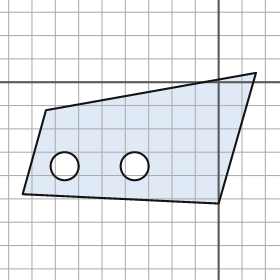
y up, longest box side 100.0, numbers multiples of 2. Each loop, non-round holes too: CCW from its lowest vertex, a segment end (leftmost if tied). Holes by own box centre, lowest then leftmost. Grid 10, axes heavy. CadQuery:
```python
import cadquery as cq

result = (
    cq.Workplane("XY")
    .moveTo(0.0, -52.0)
    .lineTo(16.0, 4.0)
    .lineTo(-74.0, -12.0)
    .lineTo(-84.0, -48.0)
    .close()
    .moveTo(-66.0, -36.0)
    .circle(6.0)
    .moveTo(-36.0, -36.0)
    .circle(6.0)
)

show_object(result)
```